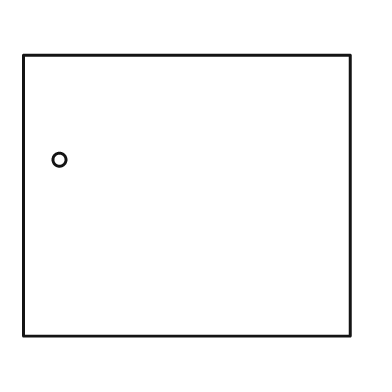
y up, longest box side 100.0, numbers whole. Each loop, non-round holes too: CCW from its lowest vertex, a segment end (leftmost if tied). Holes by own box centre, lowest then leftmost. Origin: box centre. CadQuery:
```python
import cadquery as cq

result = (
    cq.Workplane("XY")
    .moveTo(-50.0, -43.0)
    .lineTo(50.0, -43.0)
    .lineTo(50.0, 43.0)
    .lineTo(-50.0, 43.0)
    .close()
    .moveTo(-39.0, 11.0)
    .circle(2.0)
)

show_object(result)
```